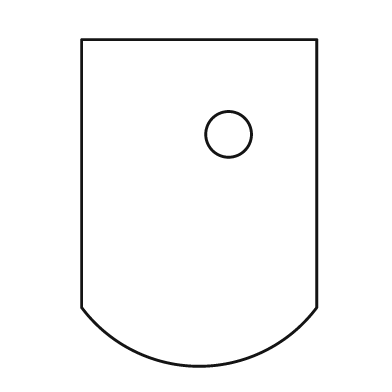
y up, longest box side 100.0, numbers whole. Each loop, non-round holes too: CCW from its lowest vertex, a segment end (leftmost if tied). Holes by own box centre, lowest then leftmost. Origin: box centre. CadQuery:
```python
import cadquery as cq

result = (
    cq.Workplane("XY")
    .moveTo(-36.0, -32.0)
    .threePointArc((0.0, -50.0), (36.0, -32.0))
    .lineTo(36.0, 50.0)
    .lineTo(-36.0, 50.0)
    .close()
    .moveTo(9.0, 21.0)
    .circle(7.0)
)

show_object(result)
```